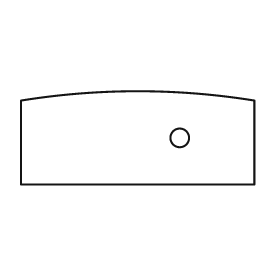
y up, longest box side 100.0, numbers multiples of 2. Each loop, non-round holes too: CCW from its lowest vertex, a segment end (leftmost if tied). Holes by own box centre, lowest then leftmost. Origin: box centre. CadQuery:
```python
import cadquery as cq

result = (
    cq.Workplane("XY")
    .moveTo(-50.0, -20.0)
    .lineTo(50.0, -20.0)
    .lineTo(50.0, 16.0)
    .threePointArc((0.0, 20.0), (-50.0, 16.0))
    .close()
    .moveTo(18.0, 0.0)
    .circle(4.0)
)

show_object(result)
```